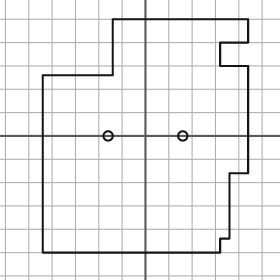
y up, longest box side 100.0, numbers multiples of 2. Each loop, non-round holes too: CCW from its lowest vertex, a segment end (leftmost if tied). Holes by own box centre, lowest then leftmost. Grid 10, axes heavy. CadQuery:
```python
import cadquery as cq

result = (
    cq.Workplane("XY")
    .moveTo(-44.0, -50.0)
    .lineTo(32.0, -50.0)
    .lineTo(32.0, -44.0)
    .lineTo(36.0, -44.0)
    .lineTo(36.0, -16.0)
    .lineTo(44.0, -16.0)
    .lineTo(44.0, 30.0)
    .lineTo(32.0, 30.0)
    .lineTo(32.0, 40.0)
    .lineTo(44.0, 40.0)
    .lineTo(44.0, 50.0)
    .lineTo(-14.0, 50.0)
    .lineTo(-14.0, 26.0)
    .lineTo(-44.0, 26.0)
    .close()
    .moveTo(-16.0, 0.0)
    .circle(2.0)
    .moveTo(16.0, 0.0)
    .circle(2.0)
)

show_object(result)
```